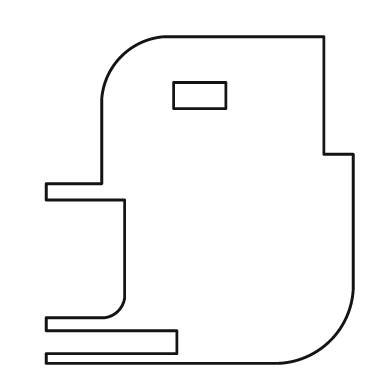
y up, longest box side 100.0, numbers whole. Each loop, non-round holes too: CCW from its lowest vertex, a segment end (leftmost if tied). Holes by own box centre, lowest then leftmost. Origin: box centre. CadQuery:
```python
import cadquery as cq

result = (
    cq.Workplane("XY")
    .moveTo(-47.0, -50.0)
    .lineTo(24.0, -50.0)
    .threePointArc((40.0, -43.0), (47.0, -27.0))
    .lineTo(47.0, 14.0)
    .lineTo(38.0, 14.0)
    .lineTo(38.0, 50.0)
    .lineTo(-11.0, 50.0)
    .threePointArc((-24.0, 44.0), (-30.0, 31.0))
    .lineTo(-30.0, 5.0)
    .lineTo(-47.0, 5.0)
    .lineTo(-47.0, 0.0)
    .lineTo(-23.0, 0.0)
    .lineTo(-23.0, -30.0)
    .threePointArc((-25.0, -34.0), (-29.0, -36.0))
    .lineTo(-47.0, -36.0)
    .lineTo(-47.0, -40.0)
    .lineTo(-7.0, -40.0)
    .lineTo(-7.0, -47.0)
    .lineTo(-47.0, -47.0)
    .close()
    .moveTo(-8.0, 28.0)
    .lineTo(8.0, 28.0)
    .lineTo(8.0, 36.0)
    .lineTo(-8.0, 36.0)
    .close()
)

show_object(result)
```